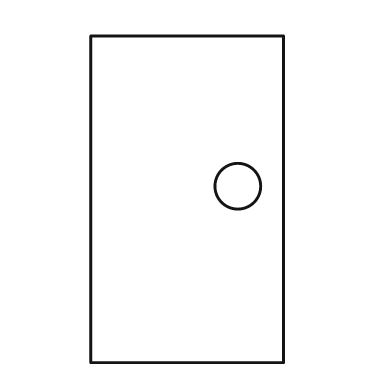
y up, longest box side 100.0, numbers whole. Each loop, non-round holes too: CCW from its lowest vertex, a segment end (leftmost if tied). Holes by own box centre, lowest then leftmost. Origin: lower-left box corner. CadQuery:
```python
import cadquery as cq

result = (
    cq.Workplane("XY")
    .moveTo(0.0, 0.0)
    .lineTo(59.0, 0.0)
    .lineTo(59.0, 100.0)
    .lineTo(0.0, 100.0)
    .close()
    .moveTo(45.0, 54.0)
    .circle(7.0)
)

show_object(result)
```